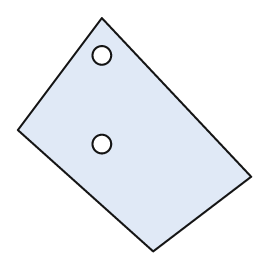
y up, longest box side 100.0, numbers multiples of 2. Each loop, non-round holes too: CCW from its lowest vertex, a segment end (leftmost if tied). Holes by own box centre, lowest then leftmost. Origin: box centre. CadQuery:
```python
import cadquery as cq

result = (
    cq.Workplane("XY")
    .moveTo(8.0, -50.0)
    .lineTo(50.0, -18.0)
    .lineTo(-14.0, 50.0)
    .lineTo(-50.0, 2.0)
    .close()
    .moveTo(-14.0, -4.0)
    .circle(4.0)
    .moveTo(-14.0, 34.0)
    .circle(4.0)
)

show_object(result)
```